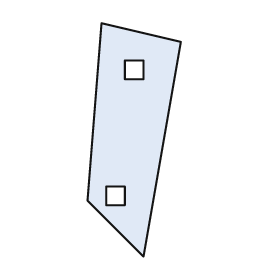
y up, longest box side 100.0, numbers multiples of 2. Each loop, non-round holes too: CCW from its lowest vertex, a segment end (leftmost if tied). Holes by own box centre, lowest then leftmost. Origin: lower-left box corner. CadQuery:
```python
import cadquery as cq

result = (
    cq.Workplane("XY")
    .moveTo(24.0, 0.0)
    .lineTo(40.0, 92.0)
    .lineTo(6.0, 100.0)
    .lineTo(0.0, 24.0)
    .close()
    .moveTo(8.0, 22.0)
    .lineTo(16.0, 22.0)
    .lineTo(16.0, 30.0)
    .lineTo(8.0, 30.0)
    .close()
    .moveTo(16.0, 76.0)
    .lineTo(24.0, 76.0)
    .lineTo(24.0, 84.0)
    .lineTo(16.0, 84.0)
    .close()
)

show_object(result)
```